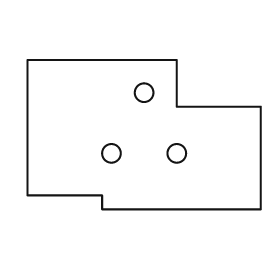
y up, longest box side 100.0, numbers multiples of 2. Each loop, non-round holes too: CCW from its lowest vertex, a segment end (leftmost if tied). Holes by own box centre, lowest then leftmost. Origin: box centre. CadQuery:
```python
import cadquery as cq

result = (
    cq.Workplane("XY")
    .moveTo(-18.0, -32.0)
    .lineTo(50.0, -32.0)
    .lineTo(50.0, 12.0)
    .lineTo(14.0, 12.0)
    .lineTo(14.0, 32.0)
    .lineTo(-50.0, 32.0)
    .lineTo(-50.0, -26.0)
    .lineTo(-18.0, -26.0)
    .close()
    .moveTo(-14.0, -8.0)
    .circle(4.0)
    .moveTo(14.0, -8.0)
    .circle(4.0)
    .moveTo(0.0, 18.0)
    .circle(4.0)
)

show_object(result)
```